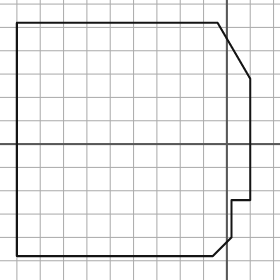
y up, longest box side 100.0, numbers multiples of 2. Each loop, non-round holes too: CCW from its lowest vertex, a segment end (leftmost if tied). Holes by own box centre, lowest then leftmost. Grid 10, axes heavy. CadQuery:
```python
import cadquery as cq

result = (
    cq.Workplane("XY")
    .moveTo(-90.0, -48.0)
    .lineTo(-6.0, -48.0)
    .lineTo(2.0, -40.0)
    .lineTo(2.0, -24.0)
    .lineTo(10.0, -24.0)
    .lineTo(10.0, 28.0)
    .lineTo(-4.0, 52.0)
    .lineTo(-90.0, 52.0)
    .close()
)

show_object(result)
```